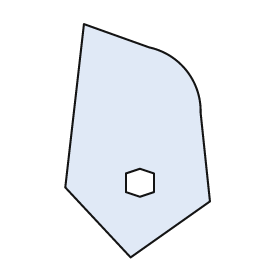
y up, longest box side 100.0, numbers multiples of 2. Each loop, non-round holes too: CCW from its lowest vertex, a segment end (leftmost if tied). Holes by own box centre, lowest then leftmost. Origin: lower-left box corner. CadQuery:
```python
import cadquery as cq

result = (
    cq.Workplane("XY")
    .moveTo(28.0, 0.0)
    .lineTo(62.0, 24.0)
    .lineTo(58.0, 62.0)
    .threePointArc((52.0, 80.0), (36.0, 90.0))
    .lineTo(8.0, 100.0)
    .lineTo(0.0, 30.0)
    .close()
    .moveTo(32.0, 26.0)
    .lineTo(38.0, 28.0)
    .lineTo(38.0, 36.0)
    .lineTo(32.0, 38.0)
    .lineTo(26.0, 36.0)
    .lineTo(26.0, 28.0)
    .close()
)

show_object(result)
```